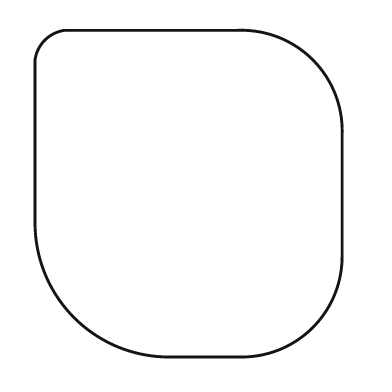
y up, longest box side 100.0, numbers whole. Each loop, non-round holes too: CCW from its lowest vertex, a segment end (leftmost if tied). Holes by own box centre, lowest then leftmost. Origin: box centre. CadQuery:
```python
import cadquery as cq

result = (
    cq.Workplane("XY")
    .moveTo(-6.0, -50.0)
    .lineTo(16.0, -50.0)
    .threePointArc((38.0, -41.0), (47.0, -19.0))
    .lineTo(47.0, 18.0)
    .threePointArc((38.0, 41.0), (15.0, 50.0))
    .lineTo(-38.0, 50.0)
    .threePointArc((-44.0, 47.0), (-47.0, 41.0))
    .lineTo(-47.0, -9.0)
    .threePointArc((-35.0, -38.0), (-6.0, -50.0))
    .close()
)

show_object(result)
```